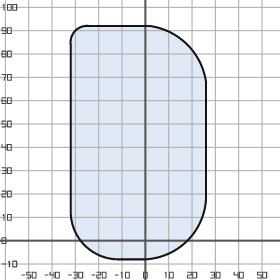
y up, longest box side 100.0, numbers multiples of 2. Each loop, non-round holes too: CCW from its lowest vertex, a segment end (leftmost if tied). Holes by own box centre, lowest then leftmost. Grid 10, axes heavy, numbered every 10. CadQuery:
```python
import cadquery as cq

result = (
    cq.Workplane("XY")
    .moveTo(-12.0, -8.0)
    .lineTo(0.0, -8.0)
    .threePointArc((18.0, 0.0), (26.0, 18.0))
    .lineTo(26.0, 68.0)
    .threePointArc((18.0, 84.0), (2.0, 92.0))
    .lineTo(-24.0, 92.0)
    .threePointArc((-30.0, 90.0), (-32.0, 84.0))
    .lineTo(-32.0, 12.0)
    .threePointArc((-26.0, -2.0), (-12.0, -8.0))
    .close()
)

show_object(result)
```